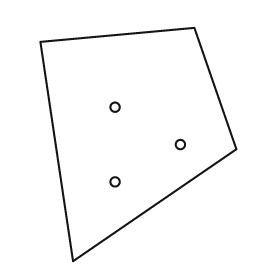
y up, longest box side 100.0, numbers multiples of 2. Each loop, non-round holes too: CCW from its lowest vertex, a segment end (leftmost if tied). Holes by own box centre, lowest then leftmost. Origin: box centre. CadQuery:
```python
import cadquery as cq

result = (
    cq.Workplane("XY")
    .moveTo(-28.0, -50.0)
    .lineTo(42.0, -2.0)
    .lineTo(24.0, 50.0)
    .lineTo(-42.0, 44.0)
    .close()
    .moveTo(-10.0, -16.0)
    .circle(2.0)
    .moveTo(18.0, 0.0)
    .circle(2.0)
    .moveTo(-10.0, 16.0)
    .circle(2.0)
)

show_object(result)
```